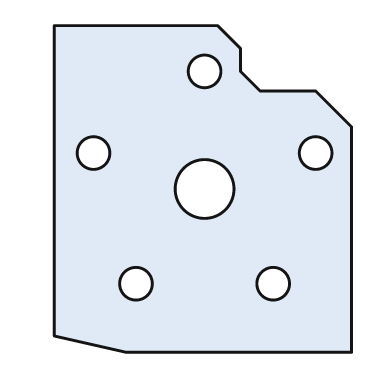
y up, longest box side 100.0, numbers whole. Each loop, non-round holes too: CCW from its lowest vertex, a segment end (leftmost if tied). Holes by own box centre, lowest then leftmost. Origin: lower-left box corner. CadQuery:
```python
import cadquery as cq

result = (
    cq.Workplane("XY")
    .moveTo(22.0, 0.0)
    .lineTo(91.0, 0.0)
    .lineTo(91.0, 69.0)
    .lineTo(80.0, 80.0)
    .lineTo(63.0, 80.0)
    .lineTo(57.0, 86.0)
    .lineTo(57.0, 93.0)
    .lineTo(50.0, 100.0)
    .lineTo(0.0, 100.0)
    .lineTo(0.0, 5.0)
    .close()
    .moveTo(25.0, 21.0)
    .circle(5.0)
    .moveTo(67.0, 21.0)
    .circle(5.0)
    .moveTo(46.0, 50.0)
    .circle(9.0)
    .moveTo(12.0, 61.0)
    .circle(5.0)
    .moveTo(80.0, 61.0)
    .circle(5.0)
    .moveTo(46.0, 86.0)
    .circle(5.0)
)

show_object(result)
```